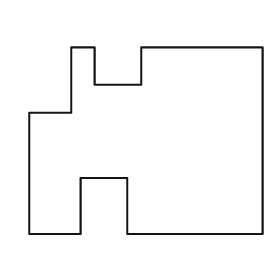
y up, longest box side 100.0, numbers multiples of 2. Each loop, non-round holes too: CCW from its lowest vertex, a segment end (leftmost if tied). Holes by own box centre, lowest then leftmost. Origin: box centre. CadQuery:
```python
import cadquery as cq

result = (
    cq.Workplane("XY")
    .moveTo(-50.0, -40.0)
    .lineTo(-28.0, -40.0)
    .lineTo(-28.0, -16.0)
    .lineTo(-8.0, -16.0)
    .lineTo(-8.0, -40.0)
    .lineTo(50.0, -40.0)
    .lineTo(50.0, 40.0)
    .lineTo(-2.0, 40.0)
    .lineTo(-2.0, 24.0)
    .lineTo(-22.0, 24.0)
    .lineTo(-22.0, 40.0)
    .lineTo(-32.0, 40.0)
    .lineTo(-32.0, 12.0)
    .lineTo(-50.0, 12.0)
    .close()
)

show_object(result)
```